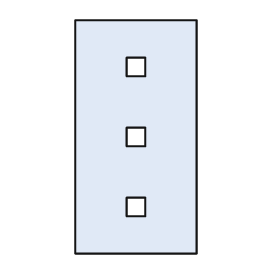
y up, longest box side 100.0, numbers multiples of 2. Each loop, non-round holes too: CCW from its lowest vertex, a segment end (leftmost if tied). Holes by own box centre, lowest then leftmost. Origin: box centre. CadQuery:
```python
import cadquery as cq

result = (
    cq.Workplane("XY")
    .moveTo(-26.0, -50.0)
    .lineTo(26.0, -50.0)
    .lineTo(26.0, 50.0)
    .lineTo(-26.0, 50.0)
    .close()
    .moveTo(-4.0, -34.0)
    .lineTo(4.0, -34.0)
    .lineTo(4.0, -26.0)
    .lineTo(-4.0, -26.0)
    .close()
    .moveTo(-4.0, -4.0)
    .lineTo(4.0, -4.0)
    .lineTo(4.0, 4.0)
    .lineTo(-4.0, 4.0)
    .close()
    .moveTo(-4.0, 26.0)
    .lineTo(4.0, 26.0)
    .lineTo(4.0, 34.0)
    .lineTo(-4.0, 34.0)
    .close()
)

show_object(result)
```